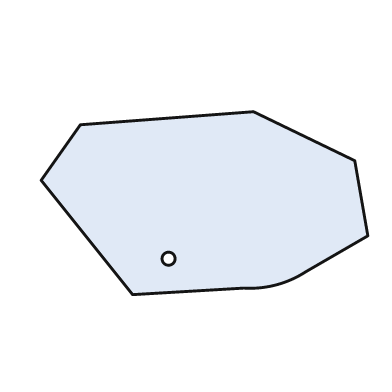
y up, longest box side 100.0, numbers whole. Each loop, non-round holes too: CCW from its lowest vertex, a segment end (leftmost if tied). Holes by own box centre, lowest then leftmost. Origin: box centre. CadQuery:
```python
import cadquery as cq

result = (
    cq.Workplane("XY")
    .moveTo(-22.0, -28.0)
    .lineTo(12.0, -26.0)
    .threePointArc((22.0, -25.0), (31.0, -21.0))
    .lineTo(50.0, -10.0)
    .lineTo(46.0, 13.0)
    .lineTo(15.0, 28.0)
    .lineTo(-38.0, 24.0)
    .lineTo(-50.0, 7.0)
    .close()
    .moveTo(-11.0, -17.0)
    .circle(2.0)
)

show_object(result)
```